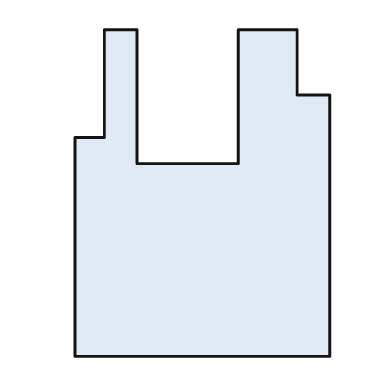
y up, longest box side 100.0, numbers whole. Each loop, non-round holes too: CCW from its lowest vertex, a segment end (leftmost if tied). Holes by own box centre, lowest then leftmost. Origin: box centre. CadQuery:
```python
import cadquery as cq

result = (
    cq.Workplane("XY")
    .moveTo(-39.0, -50.0)
    .lineTo(39.0, -50.0)
    .lineTo(39.0, 30.0)
    .lineTo(29.0, 30.0)
    .lineTo(29.0, 50.0)
    .lineTo(11.0, 50.0)
    .lineTo(11.0, 9.0)
    .lineTo(-20.0, 9.0)
    .lineTo(-20.0, 50.0)
    .lineTo(-30.0, 50.0)
    .lineTo(-30.0, 17.0)
    .lineTo(-39.0, 17.0)
    .close()
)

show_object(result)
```